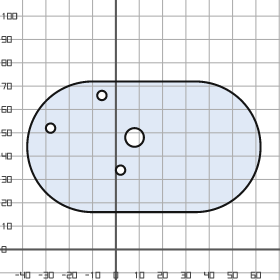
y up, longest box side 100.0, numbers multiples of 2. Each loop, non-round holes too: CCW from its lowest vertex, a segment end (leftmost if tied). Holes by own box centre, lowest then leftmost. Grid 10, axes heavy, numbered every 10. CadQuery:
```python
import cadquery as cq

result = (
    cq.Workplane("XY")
    .moveTo(-10.0, 16.0)
    .lineTo(34.0, 16.0)
    .threePointArc((62.0, 44.0), (34.0, 72.0))
    .lineTo(-10.0, 72.0)
    .threePointArc((-38.0, 44.0), (-10.0, 16.0))
    .close()
    .moveTo(2.0, 34.0)
    .circle(2.0)
    .moveTo(8.0, 48.0)
    .circle(4.0)
    .moveTo(-28.0, 52.0)
    .circle(2.0)
    .moveTo(-6.0, 66.0)
    .circle(2.0)
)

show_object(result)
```